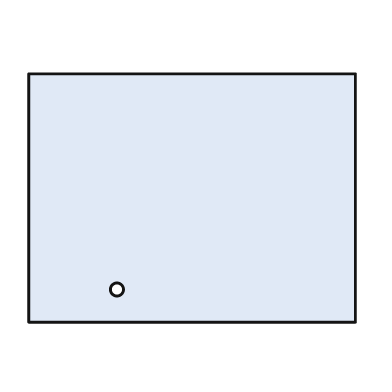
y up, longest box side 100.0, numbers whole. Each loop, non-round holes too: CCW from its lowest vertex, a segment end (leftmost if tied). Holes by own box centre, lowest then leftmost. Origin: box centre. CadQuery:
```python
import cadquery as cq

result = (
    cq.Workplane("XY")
    .moveTo(-50.0, -38.0)
    .lineTo(50.0, -38.0)
    .lineTo(50.0, 38.0)
    .lineTo(-50.0, 38.0)
    .close()
    .moveTo(-23.0, -28.0)
    .circle(2.0)
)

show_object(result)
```